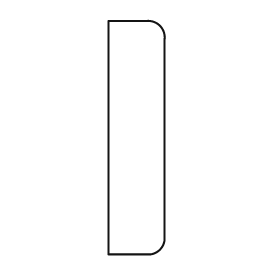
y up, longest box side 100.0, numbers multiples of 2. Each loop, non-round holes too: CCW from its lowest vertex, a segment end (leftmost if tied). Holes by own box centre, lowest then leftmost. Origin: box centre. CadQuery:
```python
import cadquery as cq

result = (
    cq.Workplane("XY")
    .moveTo(-12.0, -50.0)
    .lineTo(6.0, -50.0)
    .threePointArc((10.0, -48.0), (12.0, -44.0))
    .lineTo(12.0, 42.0)
    .threePointArc((10.0, 48.0), (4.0, 50.0))
    .lineTo(-12.0, 50.0)
    .close()
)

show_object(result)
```